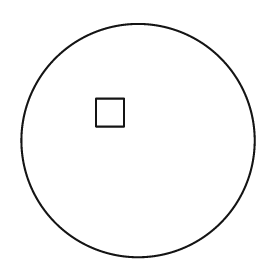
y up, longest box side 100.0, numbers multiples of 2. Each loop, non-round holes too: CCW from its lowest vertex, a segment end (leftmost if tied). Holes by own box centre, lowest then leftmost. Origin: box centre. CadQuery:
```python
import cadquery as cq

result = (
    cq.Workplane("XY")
    .moveTo(0.0, 0.0)
    .circle(50.0)
    .moveTo(-18.0, 6.0)
    .lineTo(-6.0, 6.0)
    .lineTo(-6.0, 18.0)
    .lineTo(-18.0, 18.0)
    .close()
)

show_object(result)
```